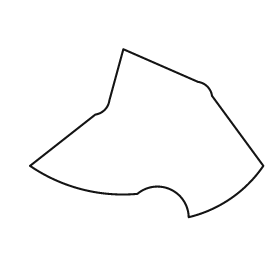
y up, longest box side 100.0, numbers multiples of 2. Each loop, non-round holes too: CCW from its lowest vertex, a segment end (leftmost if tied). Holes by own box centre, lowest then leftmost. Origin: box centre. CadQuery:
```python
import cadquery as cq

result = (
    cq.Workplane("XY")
    .moveTo(18.0, -36.0)
    .threePointArc((36.0, -28.0), (50.0, -14.0))
    .lineTo(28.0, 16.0)
    .threePointArc((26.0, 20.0), (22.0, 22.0))
    .lineTo(-10.0, 36.0)
    .lineTo(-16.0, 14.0)
    .threePointArc((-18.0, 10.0), (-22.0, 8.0))
    .lineTo(-50.0, -14.0)
    .threePointArc((-28.0, -24.0), (-4.0, -26.0))
    .threePointArc((10.0, -24.0), (18.0, -36.0))
    .close()
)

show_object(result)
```